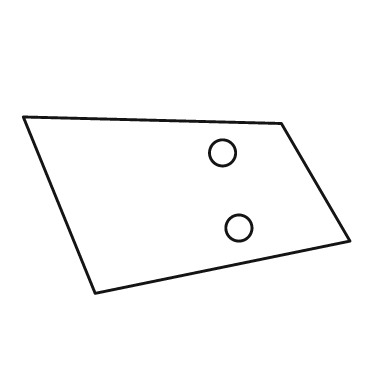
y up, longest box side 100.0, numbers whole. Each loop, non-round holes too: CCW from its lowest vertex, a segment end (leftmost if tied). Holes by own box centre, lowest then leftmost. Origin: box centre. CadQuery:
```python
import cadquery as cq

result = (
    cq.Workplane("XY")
    .moveTo(-28.0, -27.0)
    .lineTo(50.0, -11.0)
    .lineTo(29.0, 25.0)
    .lineTo(-50.0, 27.0)
    .close()
    .moveTo(16.0, -7.0)
    .circle(4.0)
    .moveTo(11.0, 16.0)
    .circle(4.0)
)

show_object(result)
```